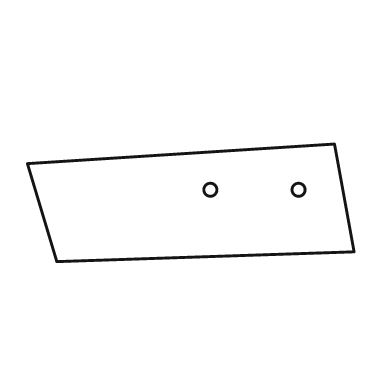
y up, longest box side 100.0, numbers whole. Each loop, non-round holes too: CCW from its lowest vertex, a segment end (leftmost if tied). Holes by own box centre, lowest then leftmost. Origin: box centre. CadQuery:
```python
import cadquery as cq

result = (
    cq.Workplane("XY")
    .moveTo(-41.0, -18.0)
    .lineTo(50.0, -15.0)
    .lineTo(44.0, 18.0)
    .lineTo(-50.0, 12.0)
    .close()
    .moveTo(6.0, 4.0)
    .circle(2.0)
    .moveTo(33.0, 4.0)
    .circle(2.0)
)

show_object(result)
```